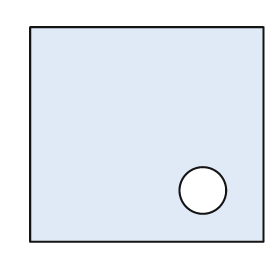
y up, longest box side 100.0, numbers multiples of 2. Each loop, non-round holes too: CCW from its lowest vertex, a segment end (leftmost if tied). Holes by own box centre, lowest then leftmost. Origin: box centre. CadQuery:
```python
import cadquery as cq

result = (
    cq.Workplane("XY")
    .moveTo(-50.0, -46.0)
    .lineTo(50.0, -46.0)
    .lineTo(50.0, 46.0)
    .lineTo(-50.0, 46.0)
    .close()
    .moveTo(24.0, -24.0)
    .circle(10.0)
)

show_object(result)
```